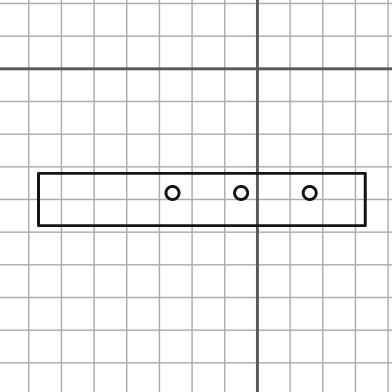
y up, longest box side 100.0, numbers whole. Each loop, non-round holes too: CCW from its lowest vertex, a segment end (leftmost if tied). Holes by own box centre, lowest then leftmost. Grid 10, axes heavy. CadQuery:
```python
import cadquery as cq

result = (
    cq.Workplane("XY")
    .moveTo(-67.0, -48.0)
    .lineTo(33.0, -48.0)
    .lineTo(33.0, -32.0)
    .lineTo(-67.0, -32.0)
    .close()
    .moveTo(-26.0, -38.0)
    .circle(2.0)
    .moveTo(-5.0, -38.0)
    .circle(2.0)
    .moveTo(16.0, -38.0)
    .circle(2.0)
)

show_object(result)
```